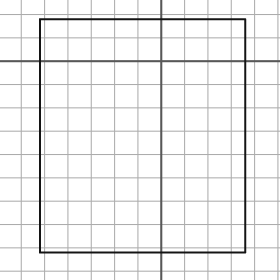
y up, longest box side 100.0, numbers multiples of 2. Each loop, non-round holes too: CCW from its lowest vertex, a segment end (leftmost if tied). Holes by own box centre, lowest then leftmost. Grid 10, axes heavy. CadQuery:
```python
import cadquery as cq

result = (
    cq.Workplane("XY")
    .moveTo(-52.0, -82.0)
    .lineTo(36.0, -82.0)
    .lineTo(36.0, 18.0)
    .lineTo(-52.0, 18.0)
    .close()
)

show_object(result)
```